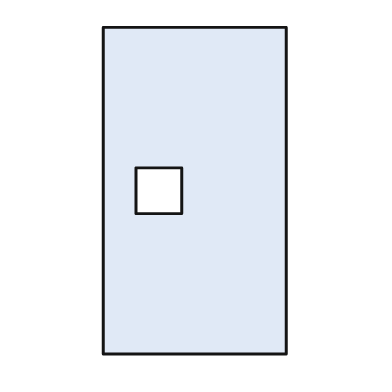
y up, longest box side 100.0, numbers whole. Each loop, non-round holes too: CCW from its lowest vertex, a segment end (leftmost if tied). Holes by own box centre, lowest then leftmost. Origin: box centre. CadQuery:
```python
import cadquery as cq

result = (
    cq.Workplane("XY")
    .moveTo(-28.0, -50.0)
    .lineTo(28.0, -50.0)
    .lineTo(28.0, 50.0)
    .lineTo(-28.0, 50.0)
    .close()
    .moveTo(-18.0, -7.0)
    .lineTo(-4.0, -7.0)
    .lineTo(-4.0, 7.0)
    .lineTo(-18.0, 7.0)
    .close()
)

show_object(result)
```